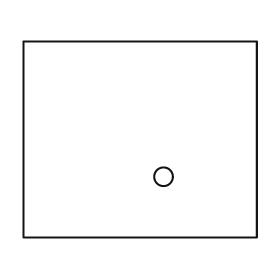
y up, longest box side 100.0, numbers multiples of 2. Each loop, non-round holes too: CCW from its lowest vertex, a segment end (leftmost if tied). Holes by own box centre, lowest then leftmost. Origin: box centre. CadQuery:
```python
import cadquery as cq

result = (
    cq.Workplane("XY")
    .moveTo(-50.0, -42.0)
    .lineTo(50.0, -42.0)
    .lineTo(50.0, 42.0)
    .lineTo(-50.0, 42.0)
    .close()
    .moveTo(10.0, -16.0)
    .circle(4.0)
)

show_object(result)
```